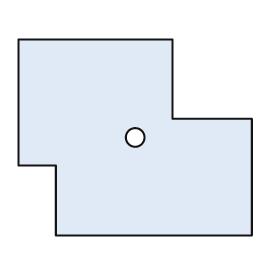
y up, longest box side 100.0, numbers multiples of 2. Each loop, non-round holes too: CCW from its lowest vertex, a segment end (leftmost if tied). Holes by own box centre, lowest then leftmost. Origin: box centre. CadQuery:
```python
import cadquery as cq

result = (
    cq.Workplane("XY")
    .moveTo(-34.0, -42.0)
    .lineTo(50.0, -42.0)
    .lineTo(50.0, 8.0)
    .lineTo(16.0, 8.0)
    .lineTo(16.0, 42.0)
    .lineTo(-50.0, 42.0)
    .lineTo(-50.0, -12.0)
    .lineTo(-34.0, -12.0)
    .close()
    .moveTo(0.0, 0.0)
    .circle(4.0)
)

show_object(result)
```